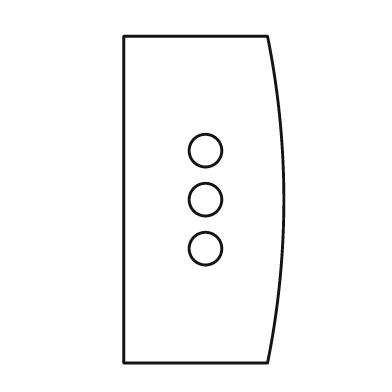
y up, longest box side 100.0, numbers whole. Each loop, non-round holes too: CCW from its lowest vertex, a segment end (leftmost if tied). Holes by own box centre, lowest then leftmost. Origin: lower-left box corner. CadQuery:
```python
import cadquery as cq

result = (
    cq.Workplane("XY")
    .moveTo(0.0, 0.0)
    .lineTo(44.0, 0.0)
    .threePointArc((49.0, 50.0), (44.0, 100.0))
    .lineTo(0.0, 100.0)
    .close()
    .moveTo(25.0, 35.0)
    .circle(5.0)
    .moveTo(25.0, 50.0)
    .circle(5.0)
    .moveTo(25.0, 65.0)
    .circle(5.0)
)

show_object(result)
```